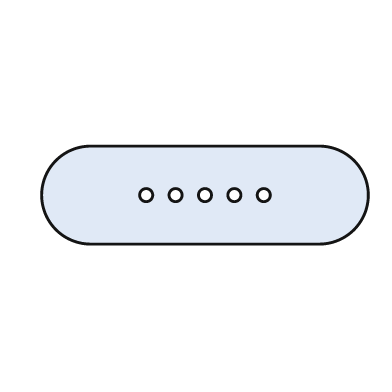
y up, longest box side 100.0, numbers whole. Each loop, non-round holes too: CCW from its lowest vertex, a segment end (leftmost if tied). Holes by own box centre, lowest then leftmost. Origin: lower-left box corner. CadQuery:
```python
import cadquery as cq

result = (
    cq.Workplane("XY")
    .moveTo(15.0, 0.0)
    .lineTo(85.0, 0.0)
    .threePointArc((100.0, 15.0), (85.0, 30.0))
    .lineTo(15.0, 30.0)
    .threePointArc((0.0, 15.0), (15.0, 0.0))
    .close()
    .moveTo(32.0, 15.0)
    .circle(2.0)
    .moveTo(41.0, 15.0)
    .circle(2.0)
    .moveTo(50.0, 15.0)
    .circle(2.0)
    .moveTo(59.0, 15.0)
    .circle(2.0)
    .moveTo(68.0, 15.0)
    .circle(2.0)
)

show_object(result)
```